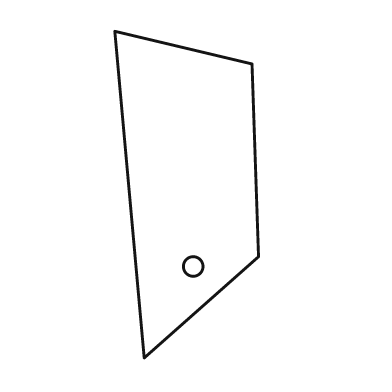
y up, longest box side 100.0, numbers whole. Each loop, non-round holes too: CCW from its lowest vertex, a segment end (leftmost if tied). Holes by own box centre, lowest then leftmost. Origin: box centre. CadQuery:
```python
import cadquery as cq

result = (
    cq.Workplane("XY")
    .moveTo(-13.0, -50.0)
    .lineTo(22.0, -19.0)
    .lineTo(20.0, 40.0)
    .lineTo(-22.0, 50.0)
    .close()
    .moveTo(2.0, -22.0)
    .circle(3.0)
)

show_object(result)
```